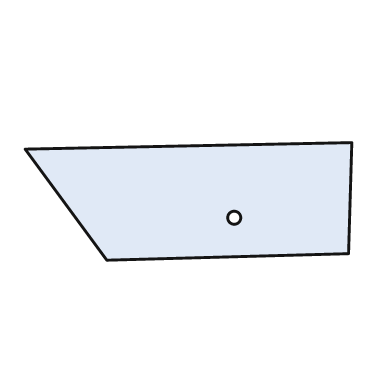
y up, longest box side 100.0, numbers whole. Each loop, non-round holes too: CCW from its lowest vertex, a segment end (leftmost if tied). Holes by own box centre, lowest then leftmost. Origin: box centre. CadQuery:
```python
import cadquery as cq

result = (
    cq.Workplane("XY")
    .moveTo(-25.0, -18.0)
    .lineTo(49.0, -16.0)
    .lineTo(50.0, 18.0)
    .lineTo(-50.0, 16.0)
    .close()
    .moveTo(14.0, -5.0)
    .circle(2.0)
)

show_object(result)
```